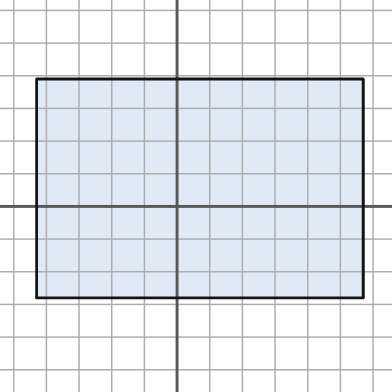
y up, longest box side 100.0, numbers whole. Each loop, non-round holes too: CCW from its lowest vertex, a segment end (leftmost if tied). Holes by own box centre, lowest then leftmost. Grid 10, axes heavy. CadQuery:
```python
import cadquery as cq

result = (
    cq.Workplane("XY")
    .moveTo(-43.0, -28.0)
    .lineTo(57.0, -28.0)
    .lineTo(57.0, 39.0)
    .lineTo(-43.0, 39.0)
    .close()
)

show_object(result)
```